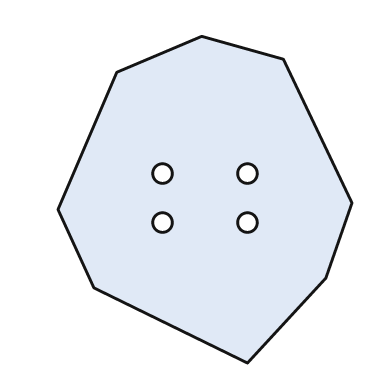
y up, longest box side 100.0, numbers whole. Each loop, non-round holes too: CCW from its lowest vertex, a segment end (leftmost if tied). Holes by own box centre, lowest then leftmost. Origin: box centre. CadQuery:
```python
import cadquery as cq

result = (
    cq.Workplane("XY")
    .moveTo(13.0, -50.0)
    .lineTo(37.0, -24.0)
    .lineTo(45.0, -1.0)
    .lineTo(24.0, 43.0)
    .lineTo(-1.0, 50.0)
    .lineTo(-27.0, 39.0)
    .lineTo(-45.0, -3.0)
    .lineTo(-34.0, -27.0)
    .close()
    .moveTo(-13.0, -7.0)
    .circle(3.0)
    .moveTo(13.0, -7.0)
    .circle(3.0)
    .moveTo(-13.0, 8.0)
    .circle(3.0)
    .moveTo(13.0, 8.0)
    .circle(3.0)
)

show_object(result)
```